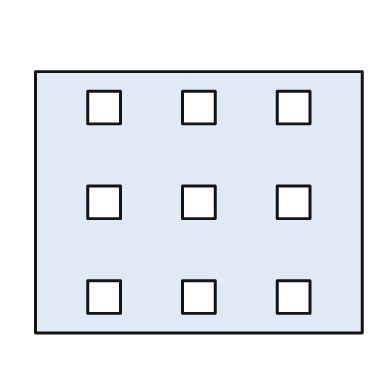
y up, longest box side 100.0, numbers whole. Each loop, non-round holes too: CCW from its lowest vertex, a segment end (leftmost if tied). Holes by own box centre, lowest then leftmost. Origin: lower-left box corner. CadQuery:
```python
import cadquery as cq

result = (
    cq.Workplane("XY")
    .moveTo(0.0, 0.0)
    .lineTo(100.0, 0.0)
    .lineTo(100.0, 80.0)
    .lineTo(0.0, 80.0)
    .close()
    .moveTo(16.0, 6.0)
    .lineTo(26.0, 6.0)
    .lineTo(26.0, 16.0)
    .lineTo(16.0, 16.0)
    .close()
    .moveTo(45.0, 6.0)
    .lineTo(55.0, 6.0)
    .lineTo(55.0, 16.0)
    .lineTo(45.0, 16.0)
    .close()
    .moveTo(74.0, 6.0)
    .lineTo(84.0, 6.0)
    .lineTo(84.0, 16.0)
    .lineTo(74.0, 16.0)
    .close()
    .moveTo(16.0, 35.0)
    .lineTo(26.0, 35.0)
    .lineTo(26.0, 45.0)
    .lineTo(16.0, 45.0)
    .close()
    .moveTo(45.0, 35.0)
    .lineTo(55.0, 35.0)
    .lineTo(55.0, 45.0)
    .lineTo(45.0, 45.0)
    .close()
    .moveTo(74.0, 35.0)
    .lineTo(84.0, 35.0)
    .lineTo(84.0, 45.0)
    .lineTo(74.0, 45.0)
    .close()
    .moveTo(16.0, 64.0)
    .lineTo(26.0, 64.0)
    .lineTo(26.0, 74.0)
    .lineTo(16.0, 74.0)
    .close()
    .moveTo(45.0, 64.0)
    .lineTo(55.0, 64.0)
    .lineTo(55.0, 74.0)
    .lineTo(45.0, 74.0)
    .close()
    .moveTo(74.0, 64.0)
    .lineTo(84.0, 64.0)
    .lineTo(84.0, 74.0)
    .lineTo(74.0, 74.0)
    .close()
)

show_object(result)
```